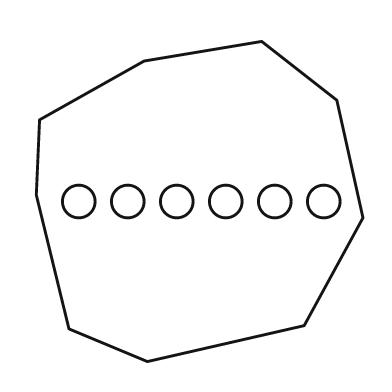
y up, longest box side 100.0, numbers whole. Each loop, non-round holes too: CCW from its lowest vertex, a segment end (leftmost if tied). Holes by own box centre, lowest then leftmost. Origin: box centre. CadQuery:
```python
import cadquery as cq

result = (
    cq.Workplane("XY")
    .moveTo(-16.0, -49.0)
    .lineTo(32.0, -38.0)
    .lineTo(50.0, -5.0)
    .lineTo(42.0, 31.0)
    .lineTo(19.0, 49.0)
    .lineTo(-17.0, 43.0)
    .lineTo(-49.0, 25.0)
    .lineTo(-50.0, 2.0)
    .lineTo(-40.0, -39.0)
    .close()
    .moveTo(-37.0, 0.0)
    .circle(5.0)
    .moveTo(-22.0, 0.0)
    .circle(5.0)
    .moveTo(-7.0, 0.0)
    .circle(5.0)
    .moveTo(8.0, 0.0)
    .circle(5.0)
    .moveTo(23.0, 0.0)
    .circle(5.0)
    .moveTo(38.0, 0.0)
    .circle(5.0)
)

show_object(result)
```